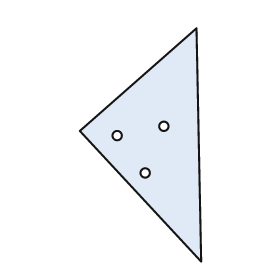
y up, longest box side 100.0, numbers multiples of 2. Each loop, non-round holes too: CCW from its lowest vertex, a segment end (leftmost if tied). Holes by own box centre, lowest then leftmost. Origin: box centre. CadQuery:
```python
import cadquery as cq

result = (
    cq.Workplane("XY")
    .moveTo(26.0, -50.0)
    .lineTo(24.0, 50.0)
    .lineTo(-26.0, 6.0)
    .close()
    .moveTo(2.0, -12.0)
    .circle(2.0)
    .moveTo(-10.0, 4.0)
    .circle(2.0)
    .moveTo(10.0, 8.0)
    .circle(2.0)
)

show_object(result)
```